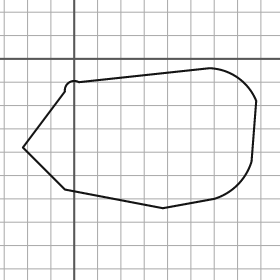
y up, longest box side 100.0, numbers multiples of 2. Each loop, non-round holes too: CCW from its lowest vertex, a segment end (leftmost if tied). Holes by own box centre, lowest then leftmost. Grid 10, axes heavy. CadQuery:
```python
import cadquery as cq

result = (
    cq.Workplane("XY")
    .moveTo(38.0, -64.0)
    .lineTo(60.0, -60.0)
    .threePointArc((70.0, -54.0), (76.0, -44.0))
    .lineTo(78.0, -18.0)
    .threePointArc((70.0, -8.0), (58.0, -4.0))
    .lineTo(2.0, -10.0)
    .threePointArc((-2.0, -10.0), (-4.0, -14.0))
    .lineTo(-22.0, -38.0)
    .lineTo(-4.0, -56.0)
    .close()
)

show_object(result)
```